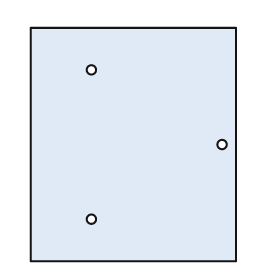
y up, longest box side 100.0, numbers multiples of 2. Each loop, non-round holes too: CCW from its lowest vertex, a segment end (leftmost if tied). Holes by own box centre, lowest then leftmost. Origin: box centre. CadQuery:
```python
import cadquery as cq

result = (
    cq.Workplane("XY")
    .moveTo(-44.0, -50.0)
    .lineTo(44.0, -50.0)
    .lineTo(44.0, 50.0)
    .lineTo(-44.0, 50.0)
    .close()
    .moveTo(-18.0, -32.0)
    .circle(2.0)
    .moveTo(38.0, 0.0)
    .circle(2.0)
    .moveTo(-18.0, 32.0)
    .circle(2.0)
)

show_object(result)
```